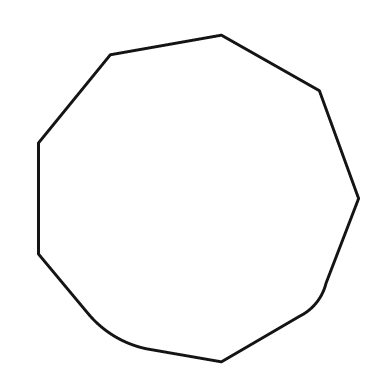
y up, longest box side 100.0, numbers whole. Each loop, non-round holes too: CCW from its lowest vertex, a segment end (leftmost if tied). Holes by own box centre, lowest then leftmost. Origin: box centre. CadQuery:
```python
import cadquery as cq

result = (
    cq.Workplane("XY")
    .moveTo(7.0, -50.0)
    .lineTo(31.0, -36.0)
    .threePointArc((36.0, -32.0), (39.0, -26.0))
    .lineTo(49.0, 0.0)
    .lineTo(37.0, 33.0)
    .lineTo(7.0, 50.0)
    .lineTo(-27.0, 44.0)
    .lineTo(-49.0, 17.0)
    .lineTo(-49.0, -17.0)
    .lineTo(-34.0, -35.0)
    .threePointArc((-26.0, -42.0), (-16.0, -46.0))
    .close()
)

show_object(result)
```